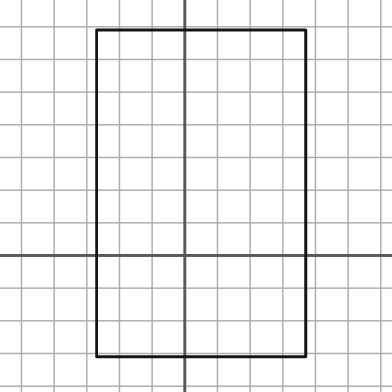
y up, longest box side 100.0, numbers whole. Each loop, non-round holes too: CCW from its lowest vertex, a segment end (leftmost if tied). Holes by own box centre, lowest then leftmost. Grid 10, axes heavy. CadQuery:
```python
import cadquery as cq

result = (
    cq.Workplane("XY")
    .moveTo(-27.0, -31.0)
    .lineTo(37.0, -31.0)
    .lineTo(37.0, 69.0)
    .lineTo(-27.0, 69.0)
    .close()
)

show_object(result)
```